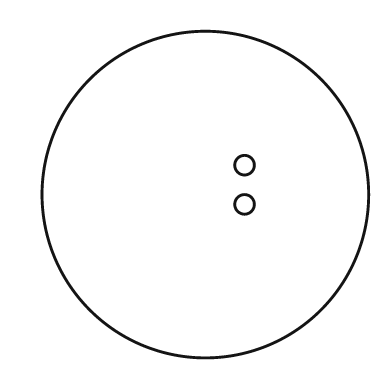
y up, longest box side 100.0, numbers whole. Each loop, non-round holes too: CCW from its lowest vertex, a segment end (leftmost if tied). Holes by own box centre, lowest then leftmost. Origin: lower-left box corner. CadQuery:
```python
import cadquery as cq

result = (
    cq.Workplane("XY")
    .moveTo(50.0, 50.0)
    .circle(50.0)
    .moveTo(62.0, 47.0)
    .circle(3.0)
    .moveTo(62.0, 59.0)
    .circle(3.0)
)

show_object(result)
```